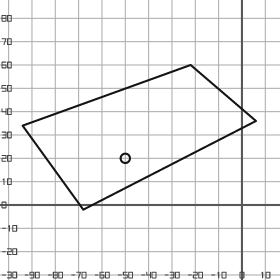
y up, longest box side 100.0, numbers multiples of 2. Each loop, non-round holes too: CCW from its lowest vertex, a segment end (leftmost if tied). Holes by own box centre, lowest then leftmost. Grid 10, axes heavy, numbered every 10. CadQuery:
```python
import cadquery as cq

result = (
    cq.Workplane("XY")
    .moveTo(-68.0, -2.0)
    .lineTo(6.0, 36.0)
    .lineTo(-22.0, 60.0)
    .lineTo(-94.0, 34.0)
    .close()
    .moveTo(-50.0, 20.0)
    .circle(2.0)
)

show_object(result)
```